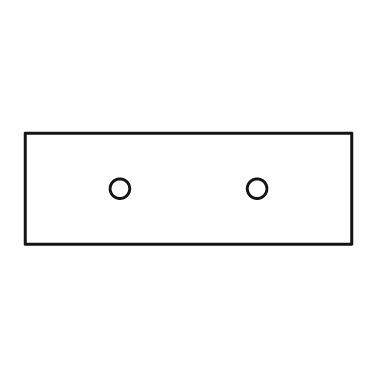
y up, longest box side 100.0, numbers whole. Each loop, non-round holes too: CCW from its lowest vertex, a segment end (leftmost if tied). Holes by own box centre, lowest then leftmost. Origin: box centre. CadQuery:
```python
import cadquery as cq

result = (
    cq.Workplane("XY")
    .moveTo(-50.0, -17.0)
    .lineTo(50.0, -17.0)
    .lineTo(50.0, 17.0)
    .lineTo(-50.0, 17.0)
    .close()
    .moveTo(-21.0, 0.0)
    .circle(3.0)
    .moveTo(21.0, 0.0)
    .circle(3.0)
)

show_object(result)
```